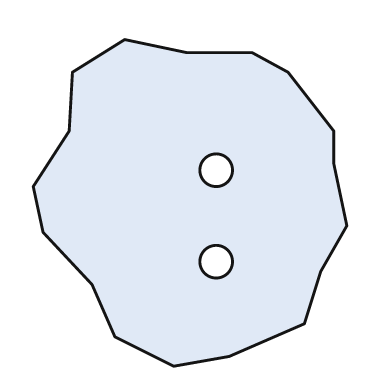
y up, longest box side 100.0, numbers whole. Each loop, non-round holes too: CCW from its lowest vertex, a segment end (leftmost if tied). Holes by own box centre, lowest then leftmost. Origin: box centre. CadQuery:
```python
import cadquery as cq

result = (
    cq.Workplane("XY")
    .moveTo(-5.0, -50.0)
    .lineTo(12.0, -47.0)
    .lineTo(35.0, -37.0)
    .lineTo(40.0, -21.0)
    .lineTo(48.0, -7.0)
    .lineTo(44.0, 12.0)
    .lineTo(44.0, 22.0)
    .lineTo(30.0, 40.0)
    .lineTo(19.0, 46.0)
    .lineTo(-1.0, 46.0)
    .lineTo(-20.0, 50.0)
    .lineTo(-36.0, 40.0)
    .lineTo(-37.0, 22.0)
    .lineTo(-48.0, 5.0)
    .lineTo(-45.0, -9.0)
    .lineTo(-30.0, -25.0)
    .lineTo(-23.0, -41.0)
    .close()
    .moveTo(8.0, -18.0)
    .circle(5.0)
    .moveTo(8.0, 10.0)
    .circle(5.0)
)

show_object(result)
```